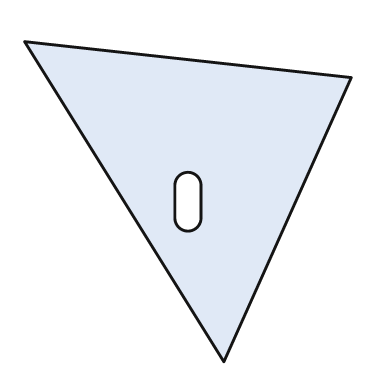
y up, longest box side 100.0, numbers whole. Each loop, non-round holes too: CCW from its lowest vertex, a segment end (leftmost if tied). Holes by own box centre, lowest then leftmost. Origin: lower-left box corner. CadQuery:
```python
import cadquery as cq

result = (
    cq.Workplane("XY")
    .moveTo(61.0, 0.0)
    .lineTo(100.0, 87.0)
    .lineTo(0.0, 98.0)
    .close()
    .moveTo(46.0, 44.0)
    .threePointArc((50.0, 40.0), (54.0, 44.0))
    .lineTo(54.0, 54.0)
    .threePointArc((50.0, 58.0), (46.0, 54.0))
    .close()
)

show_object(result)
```